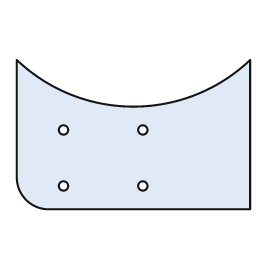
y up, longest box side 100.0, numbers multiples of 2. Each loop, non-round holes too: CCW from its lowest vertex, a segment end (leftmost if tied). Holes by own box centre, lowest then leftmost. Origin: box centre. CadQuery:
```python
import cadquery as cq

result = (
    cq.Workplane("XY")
    .moveTo(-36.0, -32.0)
    .lineTo(50.0, -32.0)
    .lineTo(50.0, 32.0)
    .threePointArc((0.0, 12.0), (-50.0, 32.0))
    .lineTo(-50.0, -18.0)
    .threePointArc((-46.0, -28.0), (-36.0, -32.0))
    .close()
    .moveTo(-30.0, -22.0)
    .circle(2.0)
    .moveTo(4.0, -22.0)
    .circle(2.0)
    .moveTo(-30.0, 2.0)
    .circle(2.0)
    .moveTo(4.0, 2.0)
    .circle(2.0)
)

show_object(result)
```